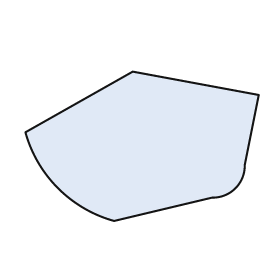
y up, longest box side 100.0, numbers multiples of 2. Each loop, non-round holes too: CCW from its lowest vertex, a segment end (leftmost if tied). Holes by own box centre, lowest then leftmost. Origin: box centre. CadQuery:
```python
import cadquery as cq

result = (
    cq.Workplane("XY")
    .moveTo(-12.0, -32.0)
    .lineTo(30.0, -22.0)
    .threePointArc((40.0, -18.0), (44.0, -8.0))
    .lineTo(50.0, 22.0)
    .lineTo(-4.0, 32.0)
    .lineTo(-50.0, 6.0)
    .threePointArc((-36.0, -18.0), (-12.0, -32.0))
    .close()
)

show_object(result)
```